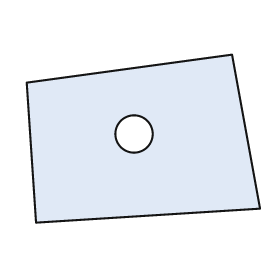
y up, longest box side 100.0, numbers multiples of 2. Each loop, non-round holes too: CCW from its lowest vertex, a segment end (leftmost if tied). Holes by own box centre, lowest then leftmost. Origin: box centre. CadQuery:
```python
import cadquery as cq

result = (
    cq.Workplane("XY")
    .moveTo(-46.0, -36.0)
    .lineTo(50.0, -30.0)
    .lineTo(38.0, 36.0)
    .lineTo(-50.0, 24.0)
    .close()
    .moveTo(-4.0, 2.0)
    .circle(8.0)
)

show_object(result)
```